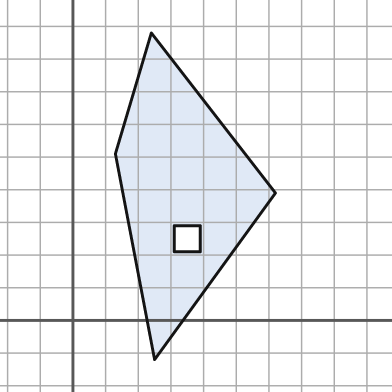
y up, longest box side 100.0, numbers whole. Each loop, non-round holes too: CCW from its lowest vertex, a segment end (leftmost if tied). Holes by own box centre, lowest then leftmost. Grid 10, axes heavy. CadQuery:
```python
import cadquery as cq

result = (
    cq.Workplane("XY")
    .moveTo(25.0, -12.0)
    .lineTo(62.0, 39.0)
    .lineTo(24.0, 88.0)
    .lineTo(13.0, 51.0)
    .close()
    .moveTo(31.0, 21.0)
    .lineTo(39.0, 21.0)
    .lineTo(39.0, 29.0)
    .lineTo(31.0, 29.0)
    .close()
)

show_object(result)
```